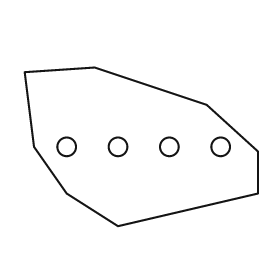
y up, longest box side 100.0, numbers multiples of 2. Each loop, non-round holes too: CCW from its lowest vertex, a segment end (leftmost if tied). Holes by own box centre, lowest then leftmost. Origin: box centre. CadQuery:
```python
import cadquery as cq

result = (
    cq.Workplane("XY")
    .moveTo(-10.0, -34.0)
    .lineTo(50.0, -20.0)
    .lineTo(50.0, -2.0)
    .lineTo(28.0, 18.0)
    .lineTo(-20.0, 34.0)
    .lineTo(-50.0, 32.0)
    .lineTo(-46.0, 0.0)
    .lineTo(-32.0, -20.0)
    .close()
    .moveTo(-32.0, 0.0)
    .circle(4.0)
    .moveTo(-10.0, 0.0)
    .circle(4.0)
    .moveTo(12.0, 0.0)
    .circle(4.0)
    .moveTo(34.0, 0.0)
    .circle(4.0)
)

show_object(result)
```